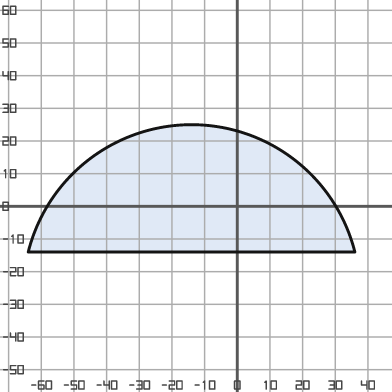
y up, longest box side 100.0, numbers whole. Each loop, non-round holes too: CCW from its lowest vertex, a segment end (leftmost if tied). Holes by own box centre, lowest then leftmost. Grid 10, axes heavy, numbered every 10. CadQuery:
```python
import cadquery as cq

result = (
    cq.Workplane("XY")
    .moveTo(-64.0, -14.0)
    .lineTo(36.0, -14.0)
    .threePointArc((-14.0, 25.0), (-64.0, -14.0))
    .close()
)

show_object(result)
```